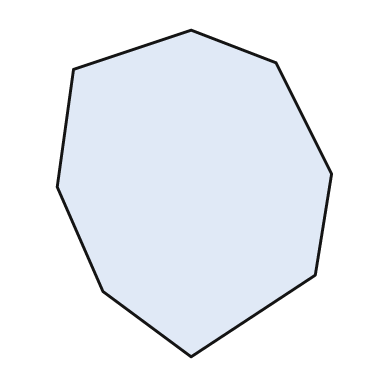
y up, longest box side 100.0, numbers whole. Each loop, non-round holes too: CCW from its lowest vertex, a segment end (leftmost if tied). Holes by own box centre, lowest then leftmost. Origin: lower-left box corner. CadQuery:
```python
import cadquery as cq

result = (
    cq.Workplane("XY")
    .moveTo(41.0, 0.0)
    .lineTo(79.0, 25.0)
    .lineTo(84.0, 56.0)
    .lineTo(67.0, 90.0)
    .lineTo(41.0, 100.0)
    .lineTo(5.0, 88.0)
    .lineTo(0.0, 52.0)
    .lineTo(14.0, 20.0)
    .close()
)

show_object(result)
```